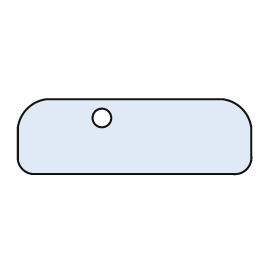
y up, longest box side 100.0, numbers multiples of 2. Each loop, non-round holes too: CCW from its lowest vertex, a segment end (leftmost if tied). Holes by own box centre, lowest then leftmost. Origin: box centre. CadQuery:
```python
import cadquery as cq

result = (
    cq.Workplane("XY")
    .moveTo(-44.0, -16.0)
    .lineTo(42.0, -16.0)
    .threePointArc((48.0, -14.0), (50.0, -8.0))
    .lineTo(50.0, 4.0)
    .threePointArc((46.0, 12.0), (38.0, 16.0))
    .lineTo(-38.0, 16.0)
    .threePointArc((-46.0, 12.0), (-50.0, 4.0))
    .lineTo(-50.0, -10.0)
    .threePointArc((-48.0, -14.0), (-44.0, -16.0))
    .close()
    .moveTo(-14.0, 8.0)
    .circle(4.0)
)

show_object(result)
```